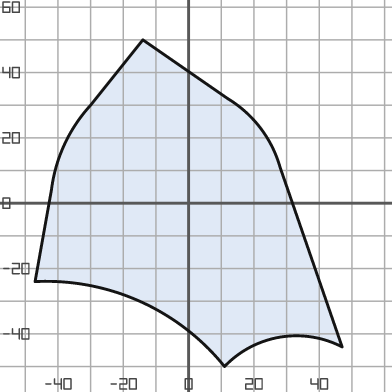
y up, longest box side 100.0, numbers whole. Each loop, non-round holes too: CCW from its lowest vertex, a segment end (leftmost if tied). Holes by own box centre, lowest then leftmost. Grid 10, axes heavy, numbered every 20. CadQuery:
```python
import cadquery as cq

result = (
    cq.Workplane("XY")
    .moveTo(11.0, -50.0)
    .threePointArc((28.0, -41.0), (47.0, -44.0))
    .lineTo(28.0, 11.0)
    .threePointArc((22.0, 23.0), (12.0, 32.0))
    .lineTo(-14.0, 50.0)
    .lineTo(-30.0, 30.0)
    .threePointArc((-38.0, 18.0), (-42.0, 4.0))
    .lineTo(-47.0, -24.0)
    .threePointArc((-15.0, -30.0), (11.0, -50.0))
    .close()
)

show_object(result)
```